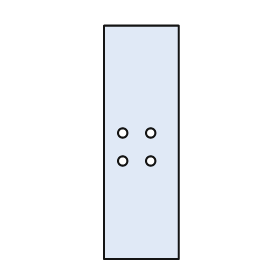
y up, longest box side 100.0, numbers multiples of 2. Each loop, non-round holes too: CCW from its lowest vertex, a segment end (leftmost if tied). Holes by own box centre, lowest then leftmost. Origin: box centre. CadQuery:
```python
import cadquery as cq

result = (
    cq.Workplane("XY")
    .moveTo(-16.0, -50.0)
    .lineTo(16.0, -50.0)
    .lineTo(16.0, 50.0)
    .lineTo(-16.0, 50.0)
    .close()
    .moveTo(-8.0, -8.0)
    .circle(2.0)
    .moveTo(4.0, -8.0)
    .circle(2.0)
    .moveTo(-8.0, 4.0)
    .circle(2.0)
    .moveTo(4.0, 4.0)
    .circle(2.0)
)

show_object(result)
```